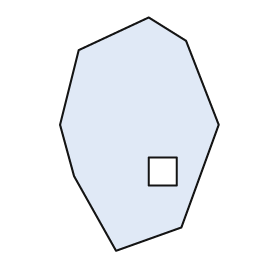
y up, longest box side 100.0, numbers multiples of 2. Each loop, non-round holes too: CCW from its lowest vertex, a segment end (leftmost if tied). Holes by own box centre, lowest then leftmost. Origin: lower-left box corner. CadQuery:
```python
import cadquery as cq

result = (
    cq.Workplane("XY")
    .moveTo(24.0, 0.0)
    .lineTo(52.0, 10.0)
    .lineTo(68.0, 54.0)
    .lineTo(54.0, 90.0)
    .lineTo(38.0, 100.0)
    .lineTo(8.0, 86.0)
    .lineTo(0.0, 54.0)
    .lineTo(6.0, 32.0)
    .close()
    .moveTo(38.0, 28.0)
    .lineTo(50.0, 28.0)
    .lineTo(50.0, 40.0)
    .lineTo(38.0, 40.0)
    .close()
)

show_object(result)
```